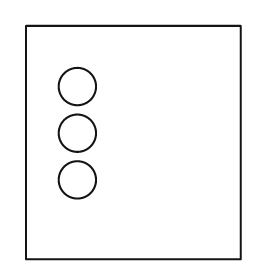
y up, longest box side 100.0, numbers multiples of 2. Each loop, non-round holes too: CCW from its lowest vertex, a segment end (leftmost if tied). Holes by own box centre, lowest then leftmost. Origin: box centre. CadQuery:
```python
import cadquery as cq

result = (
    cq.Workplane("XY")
    .moveTo(-46.0, -50.0)
    .lineTo(46.0, -50.0)
    .lineTo(46.0, 50.0)
    .lineTo(-46.0, 50.0)
    .close()
    .moveTo(-24.0, -16.0)
    .circle(8.0)
    .moveTo(-24.0, 4.0)
    .circle(8.0)
    .moveTo(-24.0, 24.0)
    .circle(8.0)
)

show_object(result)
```